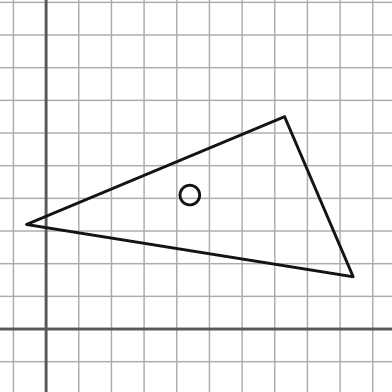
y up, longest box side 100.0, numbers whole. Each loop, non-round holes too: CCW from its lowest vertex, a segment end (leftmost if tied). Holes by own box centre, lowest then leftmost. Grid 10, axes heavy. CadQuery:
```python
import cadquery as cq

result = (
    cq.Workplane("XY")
    .moveTo(94.0, 16.0)
    .lineTo(73.0, 65.0)
    .lineTo(-6.0, 32.0)
    .close()
    .moveTo(44.0, 41.0)
    .circle(3.0)
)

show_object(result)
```